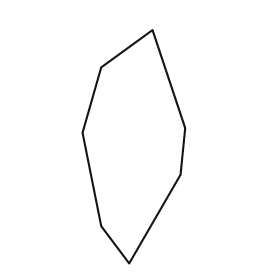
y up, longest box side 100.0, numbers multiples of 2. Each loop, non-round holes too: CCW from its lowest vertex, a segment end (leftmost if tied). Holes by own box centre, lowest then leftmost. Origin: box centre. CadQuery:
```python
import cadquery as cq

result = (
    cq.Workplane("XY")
    .moveTo(-2.0, -50.0)
    .lineTo(20.0, -12.0)
    .lineTo(22.0, 8.0)
    .lineTo(8.0, 50.0)
    .lineTo(-14.0, 34.0)
    .lineTo(-22.0, 6.0)
    .lineTo(-14.0, -34.0)
    .close()
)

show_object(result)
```